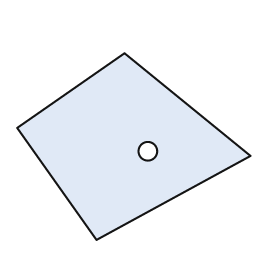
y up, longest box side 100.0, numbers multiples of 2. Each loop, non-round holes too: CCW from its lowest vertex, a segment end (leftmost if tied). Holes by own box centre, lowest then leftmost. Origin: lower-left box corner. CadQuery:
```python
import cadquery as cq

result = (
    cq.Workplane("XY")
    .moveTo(34.0, 0.0)
    .lineTo(100.0, 36.0)
    .lineTo(46.0, 80.0)
    .lineTo(0.0, 48.0)
    .close()
    .moveTo(56.0, 38.0)
    .circle(4.0)
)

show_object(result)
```